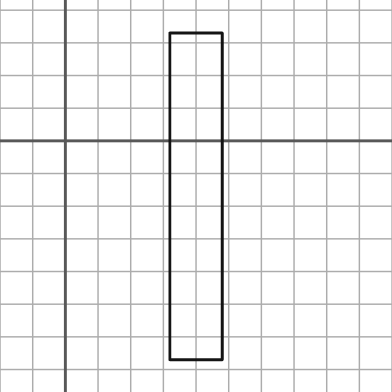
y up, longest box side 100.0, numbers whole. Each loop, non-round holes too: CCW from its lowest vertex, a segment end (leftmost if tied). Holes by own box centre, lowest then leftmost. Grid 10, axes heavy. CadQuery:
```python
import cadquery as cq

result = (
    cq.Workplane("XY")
    .moveTo(32.0, -67.0)
    .lineTo(48.0, -67.0)
    .lineTo(48.0, 33.0)
    .lineTo(32.0, 33.0)
    .close()
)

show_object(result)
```